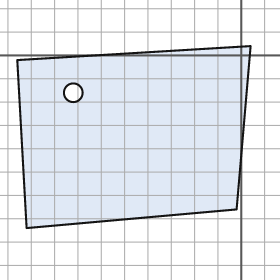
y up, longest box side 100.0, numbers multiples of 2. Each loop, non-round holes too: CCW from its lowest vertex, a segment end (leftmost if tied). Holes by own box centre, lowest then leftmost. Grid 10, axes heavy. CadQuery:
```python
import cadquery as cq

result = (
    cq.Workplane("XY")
    .moveTo(-92.0, -74.0)
    .lineTo(-2.0, -66.0)
    .lineTo(4.0, 4.0)
    .lineTo(-96.0, -2.0)
    .close()
    .moveTo(-72.0, -16.0)
    .circle(4.0)
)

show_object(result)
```